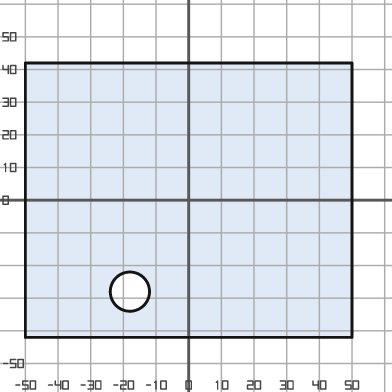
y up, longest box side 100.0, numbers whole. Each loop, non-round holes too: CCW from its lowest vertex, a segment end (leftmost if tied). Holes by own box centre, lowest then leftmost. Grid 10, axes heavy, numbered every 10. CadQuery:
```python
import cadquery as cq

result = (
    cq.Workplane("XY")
    .moveTo(-50.0, -42.0)
    .lineTo(50.0, -42.0)
    .lineTo(50.0, 42.0)
    .lineTo(-50.0, 42.0)
    .close()
    .moveTo(-18.0, -28.0)
    .circle(6.0)
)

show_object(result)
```